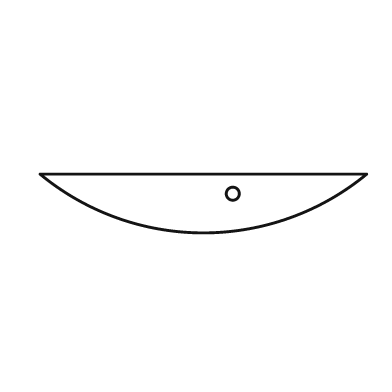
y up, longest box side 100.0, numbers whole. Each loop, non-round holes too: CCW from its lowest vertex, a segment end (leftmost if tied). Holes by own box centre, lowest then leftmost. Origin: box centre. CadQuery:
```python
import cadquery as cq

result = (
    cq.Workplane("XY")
    .moveTo(-50.0, 9.0)
    .threePointArc((0.0, -9.0), (50.0, 9.0))
    .close()
    .moveTo(9.0, 3.0)
    .circle(2.0)
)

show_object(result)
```